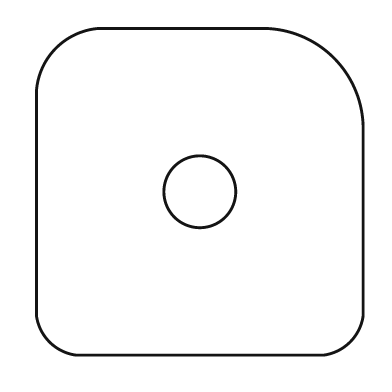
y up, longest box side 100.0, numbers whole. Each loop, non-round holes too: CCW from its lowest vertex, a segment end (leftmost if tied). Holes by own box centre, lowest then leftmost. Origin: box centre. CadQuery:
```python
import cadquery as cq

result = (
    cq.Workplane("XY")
    .moveTo(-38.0, -50.0)
    .lineTo(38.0, -50.0)
    .threePointArc((46.0, -46.0), (50.0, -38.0))
    .lineTo(50.0, 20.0)
    .threePointArc((41.0, 41.0), (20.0, 50.0))
    .lineTo(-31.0, 50.0)
    .threePointArc((-44.0, 44.0), (-50.0, 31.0))
    .lineTo(-50.0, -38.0)
    .threePointArc((-46.0, -46.0), (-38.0, -50.0))
    .close()
    .moveTo(0.0, 0.0)
    .circle(11.0)
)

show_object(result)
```